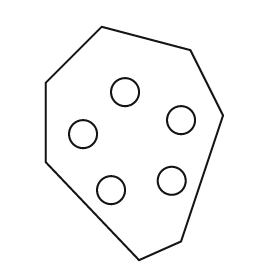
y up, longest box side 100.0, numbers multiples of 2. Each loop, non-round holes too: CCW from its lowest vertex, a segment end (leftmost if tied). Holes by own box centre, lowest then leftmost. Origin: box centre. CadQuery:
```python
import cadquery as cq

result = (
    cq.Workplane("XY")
    .moveTo(2.0, -50.0)
    .lineTo(20.0, -42.0)
    .lineTo(38.0, 12.0)
    .lineTo(24.0, 40.0)
    .lineTo(-14.0, 50.0)
    .lineTo(-38.0, 26.0)
    .lineTo(-38.0, -8.0)
    .close()
    .moveTo(-10.0, -20.0)
    .circle(6.0)
    .moveTo(16.0, -16.0)
    .circle(6.0)
    .moveTo(-22.0, 4.0)
    .circle(6.0)
    .moveTo(20.0, 10.0)
    .circle(6.0)
    .moveTo(-4.0, 22.0)
    .circle(6.0)
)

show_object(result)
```